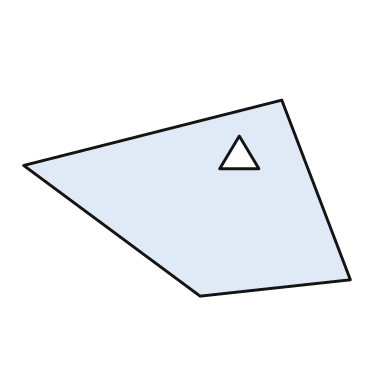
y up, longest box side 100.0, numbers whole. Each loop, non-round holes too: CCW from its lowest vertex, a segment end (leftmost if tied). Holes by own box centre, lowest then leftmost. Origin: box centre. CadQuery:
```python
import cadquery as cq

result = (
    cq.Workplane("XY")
    .moveTo(4.0, -30.0)
    .lineTo(50.0, -25.0)
    .lineTo(29.0, 30.0)
    .lineTo(-50.0, 10.0)
    .close()
    .moveTo(10.0, 9.0)
    .lineTo(22.0, 9.0)
    .lineTo(16.0, 19.0)
    .close()
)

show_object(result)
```